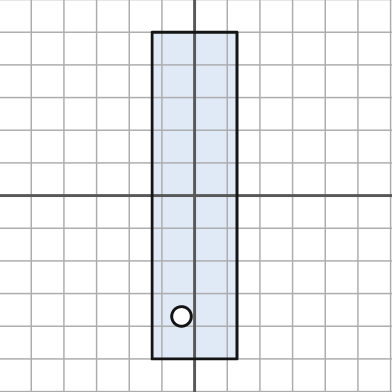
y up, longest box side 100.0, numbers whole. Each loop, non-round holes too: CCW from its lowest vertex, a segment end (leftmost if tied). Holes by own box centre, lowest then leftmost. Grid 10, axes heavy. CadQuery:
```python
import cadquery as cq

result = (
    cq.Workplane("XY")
    .moveTo(-13.0, -50.0)
    .lineTo(13.0, -50.0)
    .lineTo(13.0, 50.0)
    .lineTo(-13.0, 50.0)
    .close()
    .moveTo(-4.0, -37.0)
    .circle(3.0)
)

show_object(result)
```